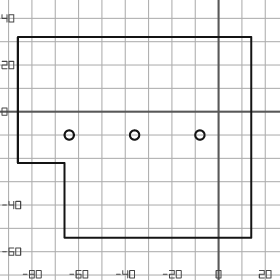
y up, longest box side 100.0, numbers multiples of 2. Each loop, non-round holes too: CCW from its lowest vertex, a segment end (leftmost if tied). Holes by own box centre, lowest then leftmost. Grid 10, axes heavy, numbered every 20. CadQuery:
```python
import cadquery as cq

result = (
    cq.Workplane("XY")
    .moveTo(-66.0, -54.0)
    .lineTo(14.0, -54.0)
    .lineTo(14.0, 32.0)
    .lineTo(-86.0, 32.0)
    .lineTo(-86.0, -22.0)
    .lineTo(-66.0, -22.0)
    .close()
    .moveTo(-64.0, -10.0)
    .circle(2.0)
    .moveTo(-36.0, -10.0)
    .circle(2.0)
    .moveTo(-8.0, -10.0)
    .circle(2.0)
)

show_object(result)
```